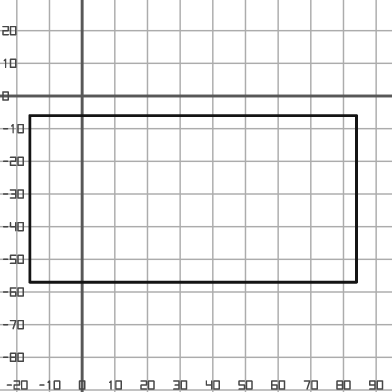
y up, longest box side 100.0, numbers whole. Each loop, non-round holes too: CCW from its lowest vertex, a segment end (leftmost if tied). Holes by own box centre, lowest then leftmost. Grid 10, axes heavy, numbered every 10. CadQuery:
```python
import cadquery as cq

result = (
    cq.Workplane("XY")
    .moveTo(-16.0, -57.0)
    .lineTo(84.0, -57.0)
    .lineTo(84.0, -6.0)
    .lineTo(-16.0, -6.0)
    .close()
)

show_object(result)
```